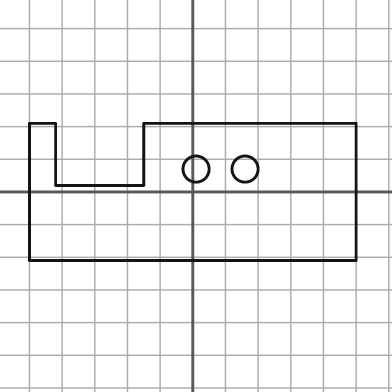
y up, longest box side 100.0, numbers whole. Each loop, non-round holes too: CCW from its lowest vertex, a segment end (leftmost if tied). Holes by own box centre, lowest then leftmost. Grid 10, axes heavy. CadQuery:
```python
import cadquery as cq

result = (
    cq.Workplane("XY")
    .moveTo(-50.0, -21.0)
    .lineTo(50.0, -21.0)
    .lineTo(50.0, 21.0)
    .lineTo(-15.0, 21.0)
    .lineTo(-15.0, 2.0)
    .lineTo(-42.0, 2.0)
    .lineTo(-42.0, 21.0)
    .lineTo(-50.0, 21.0)
    .close()
    .moveTo(1.0, 7.0)
    .circle(4.0)
    .moveTo(16.0, 7.0)
    .circle(4.0)
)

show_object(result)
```